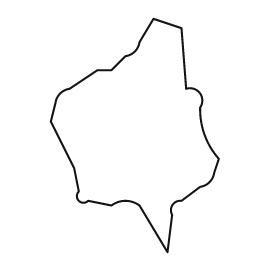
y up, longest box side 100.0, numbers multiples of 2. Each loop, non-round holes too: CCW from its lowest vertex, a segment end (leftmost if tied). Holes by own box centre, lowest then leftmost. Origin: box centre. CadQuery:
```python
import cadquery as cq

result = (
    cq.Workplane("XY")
    .moveTo(14.0, -50.0)
    .lineTo(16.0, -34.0)
    .threePointArc((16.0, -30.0), (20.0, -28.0))
    .lineTo(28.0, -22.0)
    .threePointArc((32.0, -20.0), (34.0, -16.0))
    .lineTo(36.0, -10.0)
    .threePointArc((30.0, 0.0), (28.0, 12.0))
    .threePointArc((28.0, 18.0), (22.0, 20.0))
    .lineTo(20.0, 46.0)
    .lineTo(8.0, 50.0)
    .lineTo(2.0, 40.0)
    .threePointArc((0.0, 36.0), (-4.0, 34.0))
    .lineTo(-10.0, 28.0)
    .lineTo(-16.0, 28.0)
    .lineTo(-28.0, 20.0)
    .threePointArc((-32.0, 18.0), (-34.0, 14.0))
    .lineTo(-36.0, 6.0)
    .lineTo(-26.0, -14.0)
    .lineTo(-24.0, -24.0)
    .threePointArc((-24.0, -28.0), (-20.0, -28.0))
    .lineTo(-10.0, -30.0)
    .threePointArc((-4.0, -28.0), (2.0, -30.0))
    .close()
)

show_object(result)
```